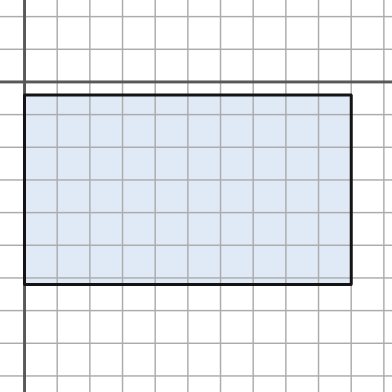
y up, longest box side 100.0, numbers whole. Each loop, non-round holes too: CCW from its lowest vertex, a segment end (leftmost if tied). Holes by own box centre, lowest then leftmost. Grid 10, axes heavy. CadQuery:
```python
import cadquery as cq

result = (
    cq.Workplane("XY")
    .moveTo(0.0, -62.0)
    .lineTo(100.0, -62.0)
    .lineTo(100.0, -4.0)
    .lineTo(0.0, -4.0)
    .close()
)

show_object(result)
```